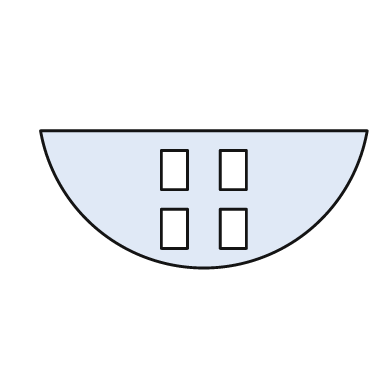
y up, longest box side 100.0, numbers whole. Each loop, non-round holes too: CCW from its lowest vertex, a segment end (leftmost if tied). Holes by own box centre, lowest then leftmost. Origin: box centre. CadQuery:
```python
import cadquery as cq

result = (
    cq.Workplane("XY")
    .moveTo(-50.0, 21.0)
    .threePointArc((0.0, -21.0), (50.0, 21.0))
    .close()
    .moveTo(-13.0, -15.0)
    .lineTo(-5.0, -15.0)
    .lineTo(-5.0, -3.0)
    .lineTo(-13.0, -3.0)
    .close()
    .moveTo(5.0, -15.0)
    .lineTo(13.0, -15.0)
    .lineTo(13.0, -3.0)
    .lineTo(5.0, -3.0)
    .close()
    .moveTo(-13.0, 3.0)
    .lineTo(-5.0, 3.0)
    .lineTo(-5.0, 15.0)
    .lineTo(-13.0, 15.0)
    .close()
    .moveTo(5.0, 3.0)
    .lineTo(13.0, 3.0)
    .lineTo(13.0, 15.0)
    .lineTo(5.0, 15.0)
    .close()
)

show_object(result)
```